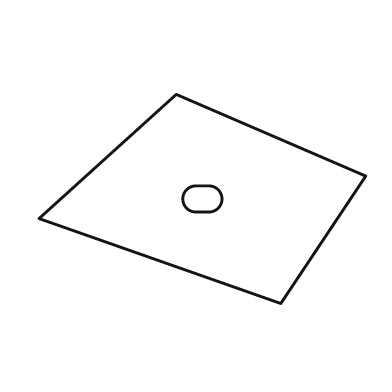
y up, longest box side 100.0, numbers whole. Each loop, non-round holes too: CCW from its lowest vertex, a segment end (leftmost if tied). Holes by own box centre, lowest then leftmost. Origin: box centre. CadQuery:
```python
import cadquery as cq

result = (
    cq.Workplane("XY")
    .moveTo(24.0, -32.0)
    .lineTo(50.0, 7.0)
    .lineTo(-8.0, 32.0)
    .lineTo(-50.0, -6.0)
    .close()
    .moveTo(-2.0, -4.0)
    .lineTo(2.0, -4.0)
    .threePointArc((6.0, 0.0), (2.0, 4.0))
    .lineTo(-2.0, 4.0)
    .threePointArc((-6.0, 0.0), (-2.0, -4.0))
    .close()
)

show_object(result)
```